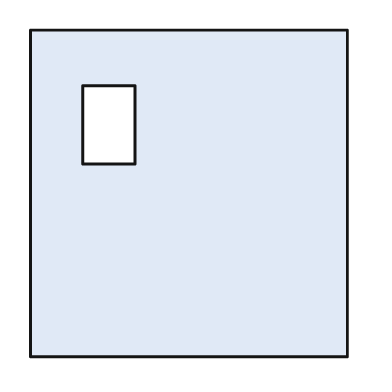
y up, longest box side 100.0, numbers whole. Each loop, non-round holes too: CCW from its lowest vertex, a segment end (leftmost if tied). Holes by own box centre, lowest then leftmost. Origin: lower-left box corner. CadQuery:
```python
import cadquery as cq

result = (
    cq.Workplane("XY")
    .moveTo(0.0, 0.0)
    .lineTo(97.0, 0.0)
    .lineTo(97.0, 100.0)
    .lineTo(0.0, 100.0)
    .close()
    .moveTo(16.0, 59.0)
    .lineTo(32.0, 59.0)
    .lineTo(32.0, 83.0)
    .lineTo(16.0, 83.0)
    .close()
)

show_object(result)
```